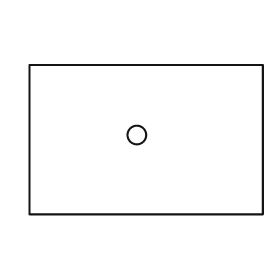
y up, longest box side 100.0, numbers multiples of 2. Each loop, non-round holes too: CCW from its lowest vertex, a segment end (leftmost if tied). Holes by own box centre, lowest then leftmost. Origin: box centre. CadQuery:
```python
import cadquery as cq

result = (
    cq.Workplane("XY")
    .moveTo(-50.0, -32.0)
    .lineTo(50.0, -32.0)
    .lineTo(50.0, 32.0)
    .lineTo(-50.0, 32.0)
    .close()
    .moveTo(-4.0, 2.0)
    .circle(4.0)
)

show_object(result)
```